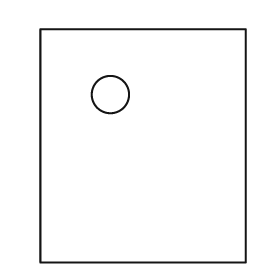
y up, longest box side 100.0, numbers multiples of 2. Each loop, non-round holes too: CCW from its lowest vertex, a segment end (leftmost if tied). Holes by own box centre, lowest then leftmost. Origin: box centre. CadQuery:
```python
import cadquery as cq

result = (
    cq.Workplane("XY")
    .moveTo(-44.0, -50.0)
    .lineTo(44.0, -50.0)
    .lineTo(44.0, 50.0)
    .lineTo(-44.0, 50.0)
    .close()
    .moveTo(-14.0, 22.0)
    .circle(8.0)
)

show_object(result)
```